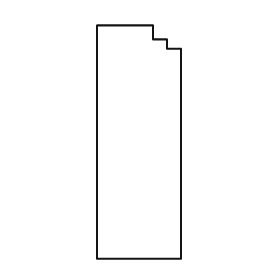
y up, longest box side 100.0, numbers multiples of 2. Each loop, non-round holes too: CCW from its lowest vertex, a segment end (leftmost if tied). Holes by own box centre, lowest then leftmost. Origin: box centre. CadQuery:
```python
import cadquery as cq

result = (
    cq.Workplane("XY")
    .moveTo(-18.0, -50.0)
    .lineTo(18.0, -50.0)
    .lineTo(18.0, 40.0)
    .lineTo(12.0, 40.0)
    .lineTo(12.0, 44.0)
    .lineTo(6.0, 44.0)
    .lineTo(6.0, 50.0)
    .lineTo(-18.0, 50.0)
    .close()
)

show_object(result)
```